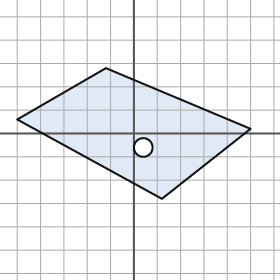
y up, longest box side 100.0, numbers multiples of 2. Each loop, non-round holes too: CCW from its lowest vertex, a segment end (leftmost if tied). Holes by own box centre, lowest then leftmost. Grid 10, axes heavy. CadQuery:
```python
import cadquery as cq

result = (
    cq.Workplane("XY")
    .moveTo(12.0, -28.0)
    .lineTo(50.0, 2.0)
    .lineTo(-12.0, 28.0)
    .lineTo(-50.0, 6.0)
    .close()
    .moveTo(4.0, -6.0)
    .circle(4.0)
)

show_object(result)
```